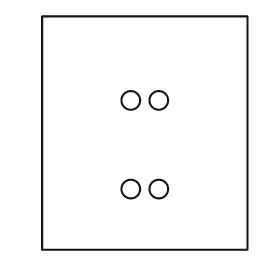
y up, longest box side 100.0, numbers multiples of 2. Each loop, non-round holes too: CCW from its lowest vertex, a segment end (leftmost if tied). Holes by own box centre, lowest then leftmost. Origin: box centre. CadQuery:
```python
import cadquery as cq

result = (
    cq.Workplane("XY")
    .moveTo(-44.0, -50.0)
    .lineTo(44.0, -50.0)
    .lineTo(44.0, 50.0)
    .lineTo(-44.0, 50.0)
    .close()
    .moveTo(-6.0, -24.0)
    .circle(4.0)
    .moveTo(6.0, -24.0)
    .circle(4.0)
    .moveTo(-6.0, 14.0)
    .circle(4.0)
    .moveTo(6.0, 14.0)
    .circle(4.0)
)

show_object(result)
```